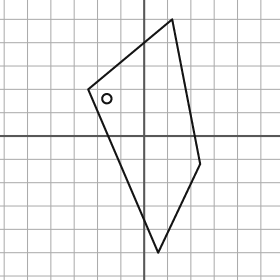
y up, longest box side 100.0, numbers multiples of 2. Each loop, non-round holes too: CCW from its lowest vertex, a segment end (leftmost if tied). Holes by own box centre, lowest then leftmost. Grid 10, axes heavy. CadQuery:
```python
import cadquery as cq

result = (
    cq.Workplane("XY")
    .moveTo(6.0, -50.0)
    .lineTo(24.0, -12.0)
    .lineTo(12.0, 50.0)
    .lineTo(-24.0, 20.0)
    .close()
    .moveTo(-16.0, 16.0)
    .circle(2.0)
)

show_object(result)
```